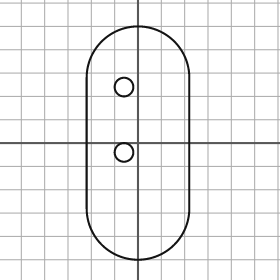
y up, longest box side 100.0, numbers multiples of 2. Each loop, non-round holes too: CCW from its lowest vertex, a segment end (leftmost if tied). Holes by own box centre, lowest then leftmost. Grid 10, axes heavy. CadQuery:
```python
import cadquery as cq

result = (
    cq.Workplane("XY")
    .moveTo(-22.0, -28.0)
    .threePointArc((0.0, -50.0), (22.0, -28.0))
    .lineTo(22.0, 28.0)
    .threePointArc((0.0, 50.0), (-22.0, 28.0))
    .close()
    .moveTo(-6.0, -4.0)
    .circle(4.0)
    .moveTo(-6.0, 24.0)
    .circle(4.0)
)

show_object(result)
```